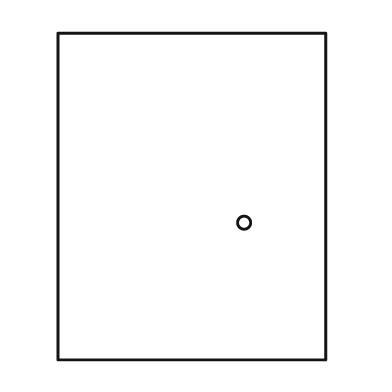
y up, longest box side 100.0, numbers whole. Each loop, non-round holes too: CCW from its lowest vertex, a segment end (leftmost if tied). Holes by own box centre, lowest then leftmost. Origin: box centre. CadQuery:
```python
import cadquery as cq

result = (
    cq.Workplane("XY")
    .moveTo(-41.0, -50.0)
    .lineTo(41.0, -50.0)
    .lineTo(41.0, 50.0)
    .lineTo(-41.0, 50.0)
    .close()
    .moveTo(16.0, -8.0)
    .circle(2.0)
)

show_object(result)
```